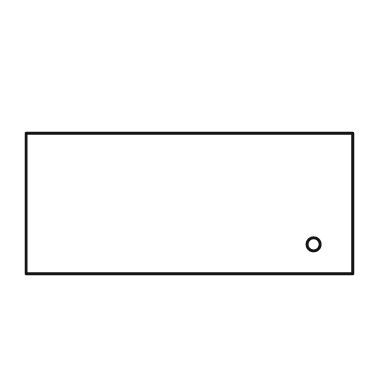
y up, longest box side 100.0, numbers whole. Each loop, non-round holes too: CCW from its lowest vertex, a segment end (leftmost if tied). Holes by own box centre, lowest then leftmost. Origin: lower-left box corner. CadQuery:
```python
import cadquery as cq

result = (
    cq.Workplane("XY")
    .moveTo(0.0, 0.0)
    .lineTo(100.0, 0.0)
    .lineTo(100.0, 43.0)
    .lineTo(0.0, 43.0)
    .close()
    .moveTo(88.0, 9.0)
    .circle(2.0)
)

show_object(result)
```